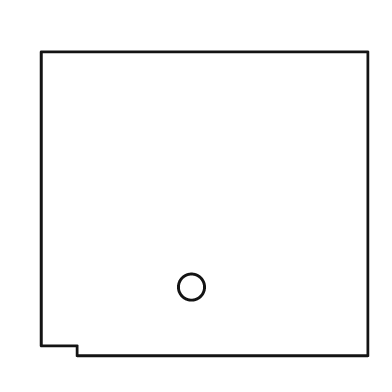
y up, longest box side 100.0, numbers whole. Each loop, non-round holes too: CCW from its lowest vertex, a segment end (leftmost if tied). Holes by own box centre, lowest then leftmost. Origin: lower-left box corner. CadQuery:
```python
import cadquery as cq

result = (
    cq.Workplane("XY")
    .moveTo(11.0, 0.0)
    .lineTo(100.0, 0.0)
    .lineTo(100.0, 93.0)
    .lineTo(0.0, 93.0)
    .lineTo(0.0, 3.0)
    .lineTo(11.0, 3.0)
    .close()
    .moveTo(46.0, 21.0)
    .circle(4.0)
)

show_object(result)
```